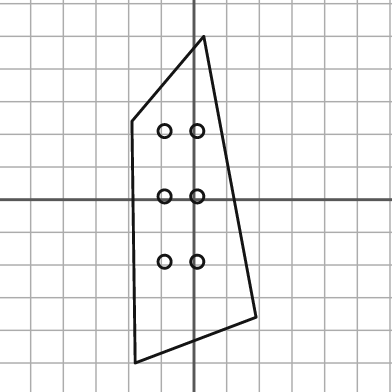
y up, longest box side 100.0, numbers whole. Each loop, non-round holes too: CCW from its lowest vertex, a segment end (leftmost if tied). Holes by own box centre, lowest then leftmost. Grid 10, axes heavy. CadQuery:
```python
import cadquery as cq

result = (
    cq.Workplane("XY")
    .moveTo(-18.0, -50.0)
    .lineTo(19.0, -36.0)
    .lineTo(3.0, 50.0)
    .lineTo(-19.0, 24.0)
    .close()
    .moveTo(-9.0, -19.0)
    .circle(2.0)
    .moveTo(1.0, -19.0)
    .circle(2.0)
    .moveTo(-9.0, 1.0)
    .circle(2.0)
    .moveTo(1.0, 1.0)
    .circle(2.0)
    .moveTo(-9.0, 21.0)
    .circle(2.0)
    .moveTo(1.0, 21.0)
    .circle(2.0)
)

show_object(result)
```